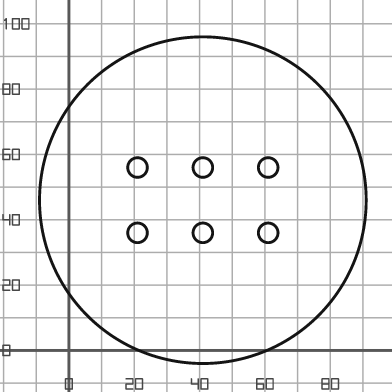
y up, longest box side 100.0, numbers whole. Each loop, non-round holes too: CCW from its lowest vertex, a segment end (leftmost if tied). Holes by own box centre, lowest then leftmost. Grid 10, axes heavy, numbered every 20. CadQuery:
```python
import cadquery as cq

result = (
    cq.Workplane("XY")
    .moveTo(41.0, 46.0)
    .circle(50.0)
    .moveTo(21.0, 36.0)
    .circle(3.0)
    .moveTo(41.0, 36.0)
    .circle(3.0)
    .moveTo(61.0, 36.0)
    .circle(3.0)
    .moveTo(21.0, 56.0)
    .circle(3.0)
    .moveTo(41.0, 56.0)
    .circle(3.0)
    .moveTo(61.0, 56.0)
    .circle(3.0)
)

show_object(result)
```